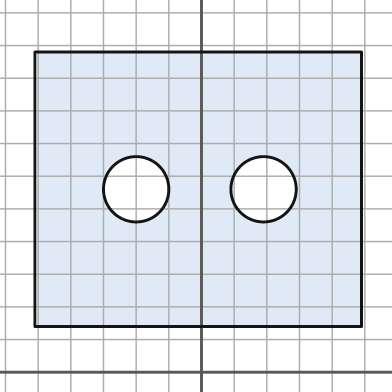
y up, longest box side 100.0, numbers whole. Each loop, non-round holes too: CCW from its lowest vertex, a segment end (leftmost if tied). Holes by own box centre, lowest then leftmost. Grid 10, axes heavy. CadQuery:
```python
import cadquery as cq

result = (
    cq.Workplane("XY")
    .moveTo(-51.0, 14.0)
    .lineTo(49.0, 14.0)
    .lineTo(49.0, 98.0)
    .lineTo(-51.0, 98.0)
    .close()
    .moveTo(-20.0, 56.0)
    .circle(10.0)
    .moveTo(19.0, 56.0)
    .circle(10.0)
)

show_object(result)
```